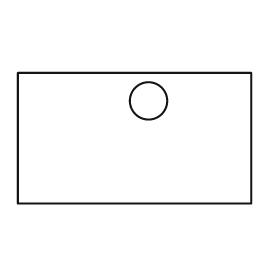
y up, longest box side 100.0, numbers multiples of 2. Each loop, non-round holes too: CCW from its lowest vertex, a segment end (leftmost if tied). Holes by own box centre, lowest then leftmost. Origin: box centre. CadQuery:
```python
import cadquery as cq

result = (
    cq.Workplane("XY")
    .moveTo(-50.0, -28.0)
    .lineTo(50.0, -28.0)
    .lineTo(50.0, 28.0)
    .lineTo(-50.0, 28.0)
    .close()
    .moveTo(6.0, 16.0)
    .circle(8.0)
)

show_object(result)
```